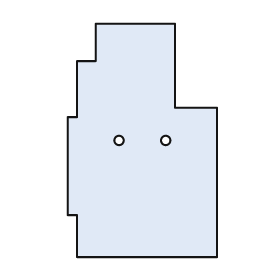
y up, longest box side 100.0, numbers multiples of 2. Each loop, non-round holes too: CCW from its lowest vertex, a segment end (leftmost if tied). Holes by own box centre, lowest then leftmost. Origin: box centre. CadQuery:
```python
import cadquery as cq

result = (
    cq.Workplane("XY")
    .moveTo(-28.0, -50.0)
    .lineTo(32.0, -50.0)
    .lineTo(32.0, 14.0)
    .lineTo(14.0, 14.0)
    .lineTo(14.0, 50.0)
    .lineTo(-20.0, 50.0)
    .lineTo(-20.0, 34.0)
    .lineTo(-28.0, 34.0)
    .lineTo(-28.0, 10.0)
    .lineTo(-32.0, 10.0)
    .lineTo(-32.0, -32.0)
    .lineTo(-28.0, -32.0)
    .close()
    .moveTo(-10.0, 0.0)
    .circle(2.0)
    .moveTo(10.0, 0.0)
    .circle(2.0)
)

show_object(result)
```